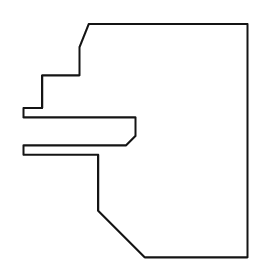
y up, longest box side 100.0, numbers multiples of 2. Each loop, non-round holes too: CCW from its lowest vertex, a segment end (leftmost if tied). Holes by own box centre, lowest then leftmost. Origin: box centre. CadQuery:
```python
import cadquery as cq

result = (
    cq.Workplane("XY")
    .moveTo(4.0, -50.0)
    .lineTo(48.0, -50.0)
    .lineTo(48.0, 50.0)
    .lineTo(-20.0, 50.0)
    .lineTo(-24.0, 40.0)
    .lineTo(-24.0, 28.0)
    .lineTo(-40.0, 28.0)
    .lineTo(-40.0, 14.0)
    .lineTo(-48.0, 14.0)
    .lineTo(-48.0, 10.0)
    .lineTo(0.0, 10.0)
    .lineTo(0.0, 2.0)
    .lineTo(-4.0, -2.0)
    .lineTo(-48.0, -2.0)
    .lineTo(-48.0, -6.0)
    .lineTo(-16.0, -6.0)
    .lineTo(-16.0, -30.0)
    .close()
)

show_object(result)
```